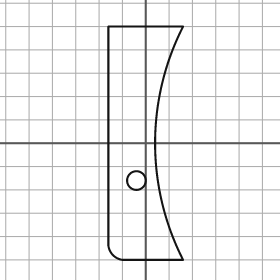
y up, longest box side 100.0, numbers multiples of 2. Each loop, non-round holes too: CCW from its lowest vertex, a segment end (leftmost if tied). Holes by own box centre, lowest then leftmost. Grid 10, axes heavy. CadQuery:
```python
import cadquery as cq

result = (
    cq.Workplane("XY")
    .moveTo(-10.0, -50.0)
    .lineTo(16.0, -50.0)
    .threePointArc((4.0, 0.0), (16.0, 50.0))
    .lineTo(-16.0, 50.0)
    .lineTo(-16.0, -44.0)
    .threePointArc((-14.0, -48.0), (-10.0, -50.0))
    .close()
    .moveTo(-4.0, -16.0)
    .circle(4.0)
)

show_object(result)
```